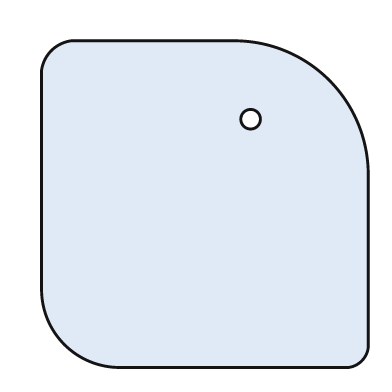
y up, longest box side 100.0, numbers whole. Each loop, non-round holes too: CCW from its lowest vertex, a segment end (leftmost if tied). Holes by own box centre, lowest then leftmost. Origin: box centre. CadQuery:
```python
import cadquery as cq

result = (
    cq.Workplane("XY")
    .moveTo(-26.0, -50.0)
    .lineTo(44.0, -50.0)
    .threePointArc((48.0, -48.0), (50.0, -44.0))
    .lineTo(50.0, 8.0)
    .threePointArc((38.0, 38.0), (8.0, 50.0))
    .lineTo(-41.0, 50.0)
    .threePointArc((-47.0, 47.0), (-50.0, 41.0))
    .lineTo(-50.0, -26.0)
    .threePointArc((-43.0, -43.0), (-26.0, -50.0))
    .close()
    .moveTo(14.0, 26.0)
    .circle(3.0)
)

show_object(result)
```